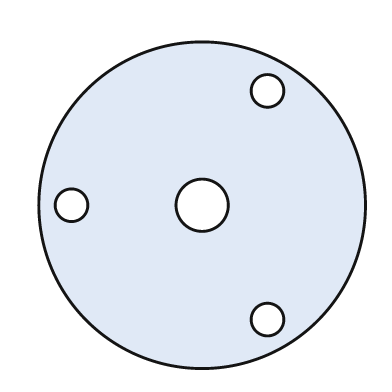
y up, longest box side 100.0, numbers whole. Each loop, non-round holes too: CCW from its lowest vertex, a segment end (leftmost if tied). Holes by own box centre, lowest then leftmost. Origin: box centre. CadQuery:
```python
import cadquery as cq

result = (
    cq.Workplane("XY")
    .moveTo(0.0, 0.0)
    .circle(50.0)
    .moveTo(20.0, -35.0)
    .circle(5.0)
    .moveTo(-40.0, 0.0)
    .circle(5.0)
    .moveTo(0.0, 0.0)
    .circle(8.0)
    .moveTo(20.0, 35.0)
    .circle(5.0)
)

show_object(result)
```